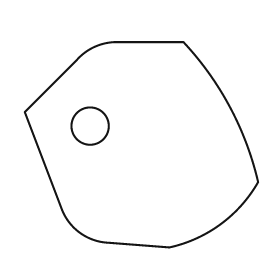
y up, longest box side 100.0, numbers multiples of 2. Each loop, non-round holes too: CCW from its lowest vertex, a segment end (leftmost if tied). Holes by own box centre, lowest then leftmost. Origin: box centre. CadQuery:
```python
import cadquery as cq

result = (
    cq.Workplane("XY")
    .moveTo(12.0, -44.0)
    .threePointArc((34.0, -34.0), (50.0, -16.0))
    .threePointArc((38.0, 16.0), (18.0, 44.0))
    .lineTo(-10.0, 44.0)
    .threePointArc((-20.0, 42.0), (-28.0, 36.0))
    .lineTo(-50.0, 14.0)
    .lineTo(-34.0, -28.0)
    .threePointArc((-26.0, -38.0), (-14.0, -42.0))
    .close()
    .moveTo(-22.0, 8.0)
    .circle(8.0)
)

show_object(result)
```